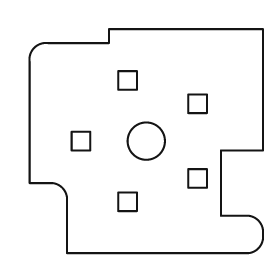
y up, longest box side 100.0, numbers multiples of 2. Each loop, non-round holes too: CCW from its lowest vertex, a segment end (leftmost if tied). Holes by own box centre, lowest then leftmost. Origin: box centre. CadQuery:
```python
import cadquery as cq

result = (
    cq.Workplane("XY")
    .moveTo(-34.0, -48.0)
    .lineTo(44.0, -48.0)
    .threePointArc((48.0, -46.0), (50.0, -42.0))
    .lineTo(50.0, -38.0)
    .threePointArc((48.0, -34.0), (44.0, -32.0))
    .lineTo(32.0, -32.0)
    .lineTo(32.0, -4.0)
    .lineTo(50.0, -4.0)
    .lineTo(50.0, 48.0)
    .lineTo(-16.0, 48.0)
    .lineTo(-16.0, 42.0)
    .lineTo(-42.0, 42.0)
    .threePointArc((-48.0, 40.0), (-50.0, 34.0))
    .lineTo(-50.0, -18.0)
    .lineTo(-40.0, -18.0)
    .threePointArc((-36.0, -20.0), (-34.0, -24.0))
    .close()
    .moveTo(-12.0, -30.0)
    .lineTo(-4.0, -30.0)
    .lineTo(-4.0, -22.0)
    .lineTo(-12.0, -22.0)
    .close()
    .moveTo(18.0, -20.0)
    .lineTo(26.0, -20.0)
    .lineTo(26.0, -12.0)
    .lineTo(18.0, -12.0)
    .close()
    .moveTo(-32.0, -4.0)
    .lineTo(-24.0, -4.0)
    .lineTo(-24.0, 4.0)
    .lineTo(-32.0, 4.0)
    .close()
    .moveTo(0.0, 0.0)
    .circle(8.0)
    .moveTo(18.0, 12.0)
    .lineTo(26.0, 12.0)
    .lineTo(26.0, 20.0)
    .lineTo(18.0, 20.0)
    .close()
    .moveTo(-12.0, 22.0)
    .lineTo(-4.0, 22.0)
    .lineTo(-4.0, 30.0)
    .lineTo(-12.0, 30.0)
    .close()
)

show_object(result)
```